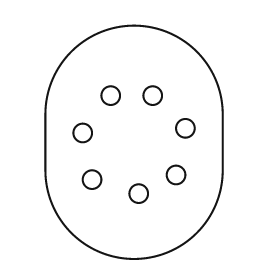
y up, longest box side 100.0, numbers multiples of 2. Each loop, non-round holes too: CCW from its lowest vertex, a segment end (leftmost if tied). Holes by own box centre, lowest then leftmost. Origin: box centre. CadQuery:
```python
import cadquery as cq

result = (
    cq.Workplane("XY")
    .moveTo(-38.0, -12.0)
    .threePointArc((0.0, -50.0), (38.0, -12.0))
    .lineTo(38.0, 12.0)
    .threePointArc((0.0, 50.0), (-38.0, 12.0))
    .close()
    .moveTo(2.0, -22.0)
    .circle(4.0)
    .moveTo(-18.0, -16.0)
    .circle(4.0)
    .moveTo(18.0, -14.0)
    .circle(4.0)
    .moveTo(-22.0, 4.0)
    .circle(4.0)
    .moveTo(22.0, 6.0)
    .circle(4.0)
    .moveTo(-10.0, 20.0)
    .circle(4.0)
    .moveTo(8.0, 20.0)
    .circle(4.0)
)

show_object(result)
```